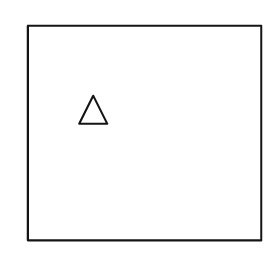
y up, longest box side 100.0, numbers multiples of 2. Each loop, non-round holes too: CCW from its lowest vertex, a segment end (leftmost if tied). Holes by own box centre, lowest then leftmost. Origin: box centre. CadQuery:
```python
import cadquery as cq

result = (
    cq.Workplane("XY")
    .moveTo(-50.0, -46.0)
    .lineTo(50.0, -46.0)
    .lineTo(50.0, 46.0)
    .lineTo(-50.0, 46.0)
    .close()
    .moveTo(-28.0, 4.0)
    .lineTo(-16.0, 4.0)
    .lineTo(-22.0, 16.0)
    .close()
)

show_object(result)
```